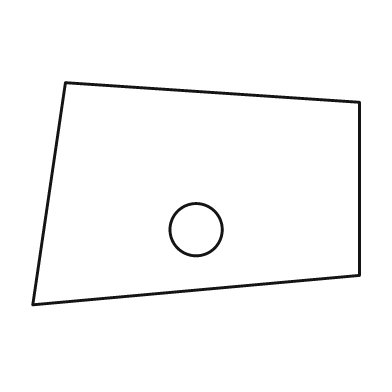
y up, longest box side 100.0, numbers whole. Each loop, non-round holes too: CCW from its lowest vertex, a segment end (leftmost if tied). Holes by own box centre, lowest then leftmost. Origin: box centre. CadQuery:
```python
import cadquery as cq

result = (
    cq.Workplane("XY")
    .moveTo(-50.0, -34.0)
    .lineTo(50.0, -25.0)
    .lineTo(50.0, 28.0)
    .lineTo(-40.0, 34.0)
    .close()
    .moveTo(0.0, -11.0)
    .circle(8.0)
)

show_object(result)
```